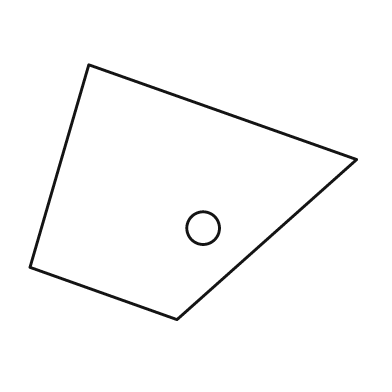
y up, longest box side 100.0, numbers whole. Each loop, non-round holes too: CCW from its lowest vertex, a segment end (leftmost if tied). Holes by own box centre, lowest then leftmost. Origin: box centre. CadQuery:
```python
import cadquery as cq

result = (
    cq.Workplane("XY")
    .moveTo(-5.0, -39.0)
    .lineTo(50.0, 10.0)
    .lineTo(-32.0, 39.0)
    .lineTo(-50.0, -23.0)
    .close()
    .moveTo(3.0, -11.0)
    .circle(5.0)
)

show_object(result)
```